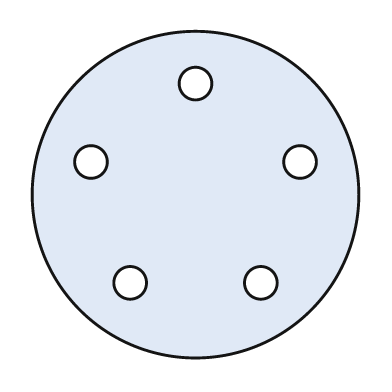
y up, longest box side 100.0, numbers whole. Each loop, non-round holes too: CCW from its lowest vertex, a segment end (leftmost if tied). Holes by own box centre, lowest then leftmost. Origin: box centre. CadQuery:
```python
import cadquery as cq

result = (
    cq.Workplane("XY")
    .moveTo(0.0, 0.0)
    .circle(50.0)
    .moveTo(-20.0, -27.0)
    .circle(5.0)
    .moveTo(20.0, -27.0)
    .circle(5.0)
    .moveTo(-32.0, 10.0)
    .circle(5.0)
    .moveTo(32.0, 10.0)
    .circle(5.0)
    .moveTo(0.0, 34.0)
    .circle(5.0)
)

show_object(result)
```